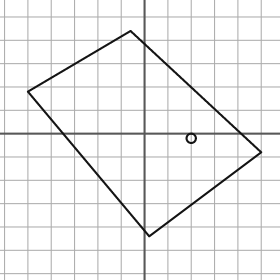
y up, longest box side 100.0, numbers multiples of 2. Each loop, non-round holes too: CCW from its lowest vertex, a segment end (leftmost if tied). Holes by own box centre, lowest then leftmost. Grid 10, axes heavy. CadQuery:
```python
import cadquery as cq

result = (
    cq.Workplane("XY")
    .moveTo(2.0, -44.0)
    .lineTo(50.0, -8.0)
    .lineTo(-6.0, 44.0)
    .lineTo(-50.0, 18.0)
    .close()
    .moveTo(20.0, -2.0)
    .circle(2.0)
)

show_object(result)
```